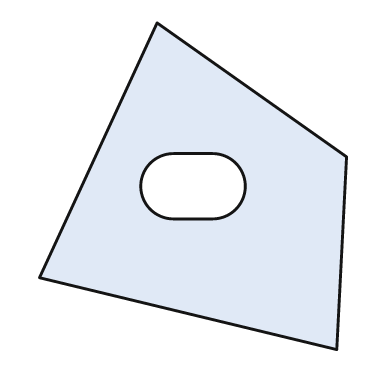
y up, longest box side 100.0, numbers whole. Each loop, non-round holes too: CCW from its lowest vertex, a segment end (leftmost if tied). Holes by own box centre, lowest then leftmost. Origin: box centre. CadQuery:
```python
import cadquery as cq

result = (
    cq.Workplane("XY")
    .moveTo(44.0, -50.0)
    .lineTo(47.0, 9.0)
    .lineTo(-11.0, 50.0)
    .lineTo(-47.0, -28.0)
    .close()
    .moveTo(-6.0, -10.0)
    .lineTo(6.0, -10.0)
    .threePointArc((16.0, 0.0), (6.0, 10.0))
    .lineTo(-6.0, 10.0)
    .threePointArc((-16.0, 0.0), (-6.0, -10.0))
    .close()
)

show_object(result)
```